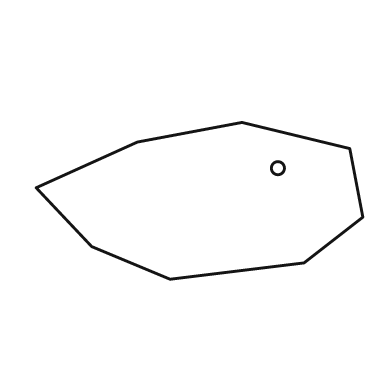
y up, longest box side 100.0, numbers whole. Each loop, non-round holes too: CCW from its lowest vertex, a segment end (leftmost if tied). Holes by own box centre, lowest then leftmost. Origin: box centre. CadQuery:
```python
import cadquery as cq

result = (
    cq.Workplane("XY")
    .moveTo(-9.0, -24.0)
    .lineTo(32.0, -19.0)
    .lineTo(50.0, -5.0)
    .lineTo(46.0, 16.0)
    .lineTo(13.0, 24.0)
    .lineTo(-19.0, 18.0)
    .lineTo(-50.0, 4.0)
    .lineTo(-33.0, -14.0)
    .close()
    .moveTo(24.0, 10.0)
    .circle(2.0)
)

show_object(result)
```